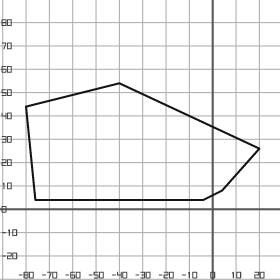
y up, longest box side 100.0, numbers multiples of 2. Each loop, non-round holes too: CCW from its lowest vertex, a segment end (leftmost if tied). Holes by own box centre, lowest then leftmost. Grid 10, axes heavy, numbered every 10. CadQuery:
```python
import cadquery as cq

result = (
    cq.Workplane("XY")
    .moveTo(-76.0, 4.0)
    .lineTo(-4.0, 4.0)
    .lineTo(4.0, 8.0)
    .lineTo(20.0, 26.0)
    .lineTo(-40.0, 54.0)
    .lineTo(-80.0, 44.0)
    .close()
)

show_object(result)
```